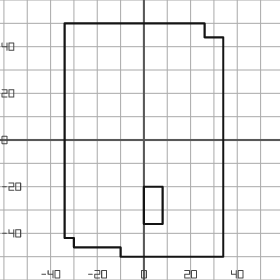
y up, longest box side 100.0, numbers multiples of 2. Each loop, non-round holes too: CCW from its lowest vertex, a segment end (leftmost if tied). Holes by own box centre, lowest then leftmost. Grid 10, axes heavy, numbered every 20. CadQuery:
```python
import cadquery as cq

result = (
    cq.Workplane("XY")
    .moveTo(-10.0, -50.0)
    .lineTo(34.0, -50.0)
    .lineTo(34.0, 44.0)
    .lineTo(26.0, 44.0)
    .lineTo(26.0, 50.0)
    .lineTo(-34.0, 50.0)
    .lineTo(-34.0, -42.0)
    .lineTo(-30.0, -42.0)
    .lineTo(-30.0, -46.0)
    .lineTo(-10.0, -46.0)
    .close()
    .moveTo(0.0, -36.0)
    .lineTo(8.0, -36.0)
    .lineTo(8.0, -20.0)
    .lineTo(0.0, -20.0)
    .close()
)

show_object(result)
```